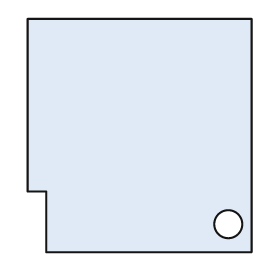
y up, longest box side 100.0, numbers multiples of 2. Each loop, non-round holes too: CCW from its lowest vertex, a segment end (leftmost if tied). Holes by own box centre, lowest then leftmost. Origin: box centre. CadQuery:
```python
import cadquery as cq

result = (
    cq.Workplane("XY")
    .moveTo(-40.0, -50.0)
    .lineTo(48.0, -50.0)
    .lineTo(48.0, 50.0)
    .lineTo(-48.0, 50.0)
    .lineTo(-48.0, -24.0)
    .lineTo(-40.0, -24.0)
    .close()
    .moveTo(38.0, -38.0)
    .circle(6.0)
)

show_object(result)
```